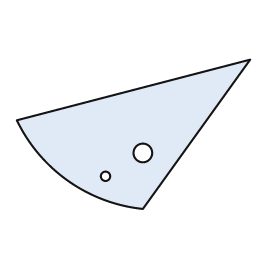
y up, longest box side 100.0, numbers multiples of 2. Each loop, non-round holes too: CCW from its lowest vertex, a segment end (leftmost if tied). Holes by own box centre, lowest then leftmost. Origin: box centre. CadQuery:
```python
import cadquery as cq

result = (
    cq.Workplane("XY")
    .moveTo(4.0, -32.0)
    .lineTo(50.0, 32.0)
    .lineTo(-50.0, 6.0)
    .threePointArc((-28.0, -20.0), (4.0, -32.0))
    .close()
    .moveTo(-12.0, -18.0)
    .circle(2.0)
    .moveTo(4.0, -8.0)
    .circle(4.0)
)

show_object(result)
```